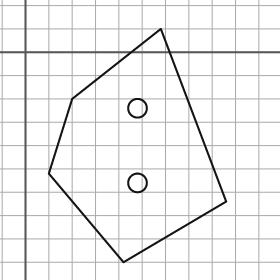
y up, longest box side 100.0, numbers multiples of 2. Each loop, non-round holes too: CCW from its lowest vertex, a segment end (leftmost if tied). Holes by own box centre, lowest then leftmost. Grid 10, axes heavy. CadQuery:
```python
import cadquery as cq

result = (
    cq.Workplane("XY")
    .moveTo(42.0, -90.0)
    .lineTo(86.0, -64.0)
    .lineTo(58.0, 10.0)
    .lineTo(20.0, -20.0)
    .lineTo(10.0, -52.0)
    .close()
    .moveTo(48.0, -56.0)
    .circle(4.0)
    .moveTo(48.0, -24.0)
    .circle(4.0)
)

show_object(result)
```